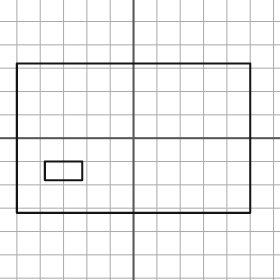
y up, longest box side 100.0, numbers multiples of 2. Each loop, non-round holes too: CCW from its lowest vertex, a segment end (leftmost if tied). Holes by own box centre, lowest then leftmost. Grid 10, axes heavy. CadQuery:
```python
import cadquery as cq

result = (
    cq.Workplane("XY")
    .moveTo(-50.0, -32.0)
    .lineTo(50.0, -32.0)
    .lineTo(50.0, 32.0)
    .lineTo(-50.0, 32.0)
    .close()
    .moveTo(-38.0, -18.0)
    .lineTo(-22.0, -18.0)
    .lineTo(-22.0, -10.0)
    .lineTo(-38.0, -10.0)
    .close()
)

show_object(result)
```